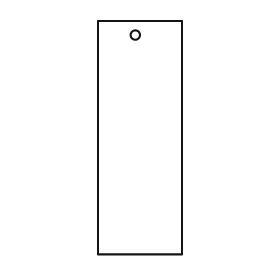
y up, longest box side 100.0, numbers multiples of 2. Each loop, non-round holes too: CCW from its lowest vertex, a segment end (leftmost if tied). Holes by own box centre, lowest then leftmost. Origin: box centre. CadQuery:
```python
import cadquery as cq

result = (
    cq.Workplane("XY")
    .moveTo(-18.0, -50.0)
    .lineTo(18.0, -50.0)
    .lineTo(18.0, 50.0)
    .lineTo(-18.0, 50.0)
    .close()
    .moveTo(-2.0, 44.0)
    .circle(2.0)
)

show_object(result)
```